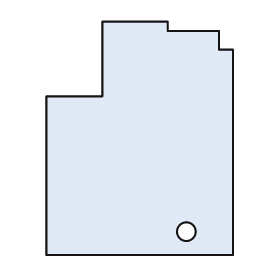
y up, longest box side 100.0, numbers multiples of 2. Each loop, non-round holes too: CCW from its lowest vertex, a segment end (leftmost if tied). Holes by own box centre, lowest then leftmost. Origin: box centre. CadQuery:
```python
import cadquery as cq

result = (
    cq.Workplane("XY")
    .moveTo(-40.0, -50.0)
    .lineTo(40.0, -50.0)
    .lineTo(40.0, 38.0)
    .lineTo(34.0, 38.0)
    .lineTo(34.0, 46.0)
    .lineTo(12.0, 46.0)
    .lineTo(12.0, 50.0)
    .lineTo(-16.0, 50.0)
    .lineTo(-16.0, 18.0)
    .lineTo(-40.0, 18.0)
    .close()
    .moveTo(20.0, -40.0)
    .circle(4.0)
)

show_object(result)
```